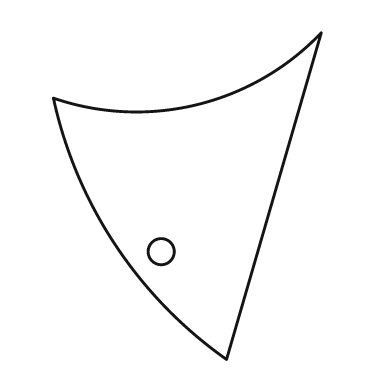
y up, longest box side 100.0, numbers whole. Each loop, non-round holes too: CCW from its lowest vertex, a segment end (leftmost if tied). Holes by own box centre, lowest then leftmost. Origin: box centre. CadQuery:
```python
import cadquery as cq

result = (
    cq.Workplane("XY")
    .moveTo(12.0, -50.0)
    .lineTo(41.0, 50.0)
    .threePointArc((3.0, 28.0), (-41.0, 30.0))
    .threePointArc((-22.0, -15.0), (12.0, -50.0))
    .close()
    .moveTo(-8.0, -17.0)
    .circle(4.0)
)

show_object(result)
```